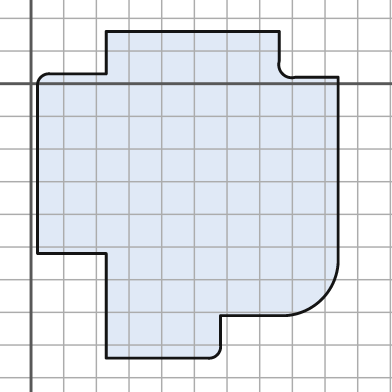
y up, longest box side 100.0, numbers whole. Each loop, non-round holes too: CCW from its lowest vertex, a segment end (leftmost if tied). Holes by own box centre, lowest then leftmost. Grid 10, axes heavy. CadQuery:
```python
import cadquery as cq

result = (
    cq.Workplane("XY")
    .moveTo(23.0, -84.0)
    .lineTo(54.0, -84.0)
    .threePointArc((57.0, -83.0), (58.0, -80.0))
    .lineTo(58.0, -71.0)
    .lineTo(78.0, -71.0)
    .threePointArc((89.0, -66.0), (94.0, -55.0))
    .lineTo(94.0, 2.0)
    .lineTo(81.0, 2.0)
    .threePointArc((77.0, 3.0), (76.0, 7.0))
    .lineTo(76.0, 16.0)
    .lineTo(23.0, 16.0)
    .lineTo(23.0, 3.0)
    .lineTo(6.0, 3.0)
    .threePointArc((3.0, 2.0), (2.0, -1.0))
    .lineTo(2.0, -52.0)
    .lineTo(23.0, -52.0)
    .close()
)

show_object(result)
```